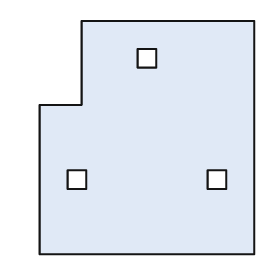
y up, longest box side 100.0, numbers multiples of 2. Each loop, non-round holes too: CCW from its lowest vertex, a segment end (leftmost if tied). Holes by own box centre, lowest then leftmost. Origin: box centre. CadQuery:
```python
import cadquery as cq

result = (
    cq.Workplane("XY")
    .moveTo(-46.0, -50.0)
    .lineTo(46.0, -50.0)
    .lineTo(46.0, 50.0)
    .lineTo(-28.0, 50.0)
    .lineTo(-28.0, 14.0)
    .lineTo(-46.0, 14.0)
    .close()
    .moveTo(-34.0, -22.0)
    .lineTo(-26.0, -22.0)
    .lineTo(-26.0, -14.0)
    .lineTo(-34.0, -14.0)
    .close()
    .moveTo(26.0, -22.0)
    .lineTo(34.0, -22.0)
    .lineTo(34.0, -14.0)
    .lineTo(26.0, -14.0)
    .close()
    .moveTo(-4.0, 30.0)
    .lineTo(4.0, 30.0)
    .lineTo(4.0, 38.0)
    .lineTo(-4.0, 38.0)
    .close()
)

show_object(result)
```